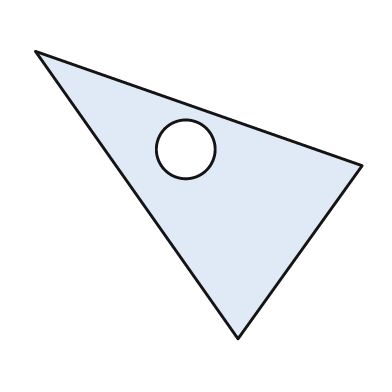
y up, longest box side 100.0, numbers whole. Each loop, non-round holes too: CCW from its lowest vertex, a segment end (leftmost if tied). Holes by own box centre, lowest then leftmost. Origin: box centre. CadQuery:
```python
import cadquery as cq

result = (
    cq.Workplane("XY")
    .moveTo(12.0, -44.0)
    .lineTo(50.0, 9.0)
    .lineTo(-50.0, 44.0)
    .close()
    .moveTo(-4.0, 14.0)
    .circle(9.0)
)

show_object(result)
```